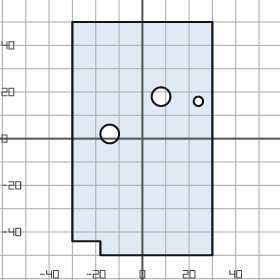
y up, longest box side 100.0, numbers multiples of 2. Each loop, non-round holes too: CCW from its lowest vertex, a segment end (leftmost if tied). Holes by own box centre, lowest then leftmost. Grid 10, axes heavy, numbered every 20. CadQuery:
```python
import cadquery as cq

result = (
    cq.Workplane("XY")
    .moveTo(-18.0, -50.0)
    .lineTo(30.0, -50.0)
    .lineTo(30.0, 50.0)
    .lineTo(-30.0, 50.0)
    .lineTo(-30.0, -44.0)
    .lineTo(-18.0, -44.0)
    .close()
    .moveTo(-14.0, 2.0)
    .circle(4.0)
    .moveTo(24.0, 16.0)
    .circle(2.0)
    .moveTo(8.0, 18.0)
    .circle(4.0)
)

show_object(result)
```